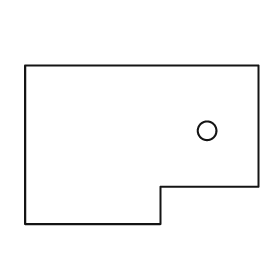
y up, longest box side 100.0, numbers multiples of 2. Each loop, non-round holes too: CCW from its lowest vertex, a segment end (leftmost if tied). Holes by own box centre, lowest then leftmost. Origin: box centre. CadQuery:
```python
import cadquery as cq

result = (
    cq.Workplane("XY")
    .moveTo(-50.0, -34.0)
    .lineTo(8.0, -34.0)
    .lineTo(8.0, -18.0)
    .lineTo(50.0, -18.0)
    .lineTo(50.0, 34.0)
    .lineTo(-50.0, 34.0)
    .close()
    .moveTo(28.0, 6.0)
    .circle(4.0)
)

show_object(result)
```